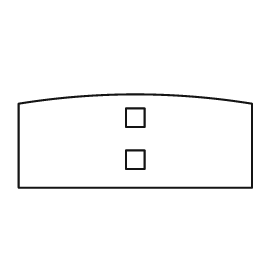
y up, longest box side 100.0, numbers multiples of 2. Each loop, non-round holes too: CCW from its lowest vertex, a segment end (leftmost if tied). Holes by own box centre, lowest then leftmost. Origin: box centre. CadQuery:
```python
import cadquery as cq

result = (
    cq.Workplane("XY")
    .moveTo(-50.0, -20.0)
    .lineTo(50.0, -20.0)
    .lineTo(50.0, 16.0)
    .threePointArc((0.0, 20.0), (-50.0, 16.0))
    .close()
    .moveTo(-4.0, -12.0)
    .lineTo(4.0, -12.0)
    .lineTo(4.0, -4.0)
    .lineTo(-4.0, -4.0)
    .close()
    .moveTo(-4.0, 6.0)
    .lineTo(4.0, 6.0)
    .lineTo(4.0, 14.0)
    .lineTo(-4.0, 14.0)
    .close()
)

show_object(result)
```